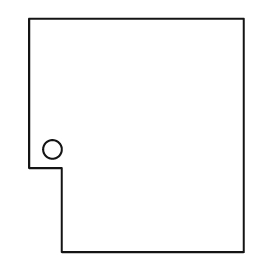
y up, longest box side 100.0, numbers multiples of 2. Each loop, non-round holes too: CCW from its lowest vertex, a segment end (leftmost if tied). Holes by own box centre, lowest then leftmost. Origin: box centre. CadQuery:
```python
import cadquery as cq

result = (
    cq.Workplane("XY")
    .moveTo(-32.0, -50.0)
    .lineTo(46.0, -50.0)
    .lineTo(46.0, 50.0)
    .lineTo(-46.0, 50.0)
    .lineTo(-46.0, -14.0)
    .lineTo(-32.0, -14.0)
    .close()
    .moveTo(-36.0, -6.0)
    .circle(4.0)
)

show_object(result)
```